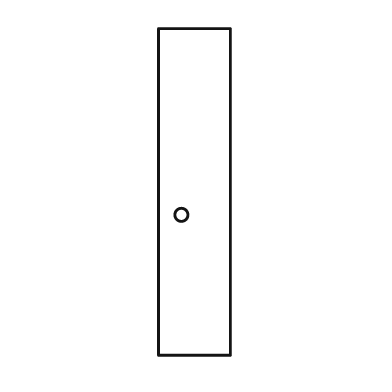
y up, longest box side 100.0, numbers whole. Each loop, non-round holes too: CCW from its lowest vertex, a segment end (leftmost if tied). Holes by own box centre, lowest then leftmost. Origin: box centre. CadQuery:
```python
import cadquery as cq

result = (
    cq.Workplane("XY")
    .moveTo(-11.0, -50.0)
    .lineTo(11.0, -50.0)
    .lineTo(11.0, 50.0)
    .lineTo(-11.0, 50.0)
    .close()
    .moveTo(-4.0, -7.0)
    .circle(2.0)
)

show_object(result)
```